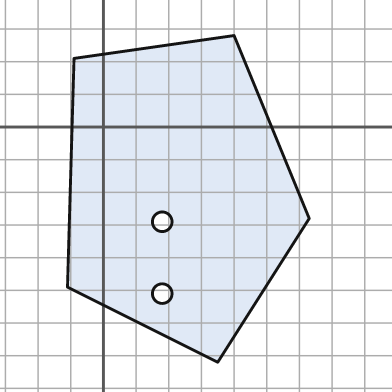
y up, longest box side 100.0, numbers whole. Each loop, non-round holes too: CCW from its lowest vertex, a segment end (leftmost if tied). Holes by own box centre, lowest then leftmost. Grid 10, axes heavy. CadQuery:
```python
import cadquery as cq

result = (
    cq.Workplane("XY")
    .moveTo(35.0, -72.0)
    .lineTo(63.0, -28.0)
    .lineTo(40.0, 28.0)
    .lineTo(-9.0, 21.0)
    .lineTo(-11.0, -49.0)
    .close()
    .moveTo(18.0, -51.0)
    .circle(3.0)
    .moveTo(18.0, -29.0)
    .circle(3.0)
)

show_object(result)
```